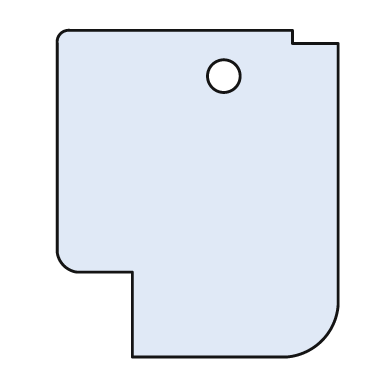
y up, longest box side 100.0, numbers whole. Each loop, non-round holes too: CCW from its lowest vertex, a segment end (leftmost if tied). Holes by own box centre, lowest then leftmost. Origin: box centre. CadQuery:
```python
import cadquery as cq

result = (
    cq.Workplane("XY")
    .moveTo(-20.0, -50.0)
    .lineTo(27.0, -50.0)
    .threePointArc((38.0, -45.0), (43.0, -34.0))
    .lineTo(43.0, 46.0)
    .lineTo(29.0, 46.0)
    .lineTo(29.0, 50.0)
    .lineTo(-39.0, 50.0)
    .threePointArc((-42.0, 49.0), (-43.0, 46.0))
    .lineTo(-43.0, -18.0)
    .threePointArc((-41.0, -22.0), (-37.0, -24.0))
    .lineTo(-20.0, -24.0)
    .close()
    .moveTo(8.0, 36.0)
    .circle(5.0)
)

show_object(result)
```